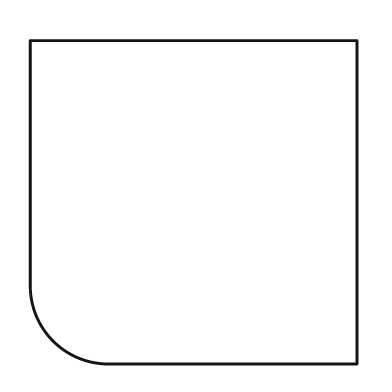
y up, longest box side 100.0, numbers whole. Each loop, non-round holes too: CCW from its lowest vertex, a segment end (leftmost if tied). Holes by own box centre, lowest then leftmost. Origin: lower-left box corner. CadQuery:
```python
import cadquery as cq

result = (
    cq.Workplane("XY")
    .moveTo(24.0, 0.0)
    .lineTo(100.0, 0.0)
    .lineTo(100.0, 99.0)
    .lineTo(0.0, 99.0)
    .lineTo(0.0, 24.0)
    .threePointArc((7.0, 7.0), (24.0, 0.0))
    .close()
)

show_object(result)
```